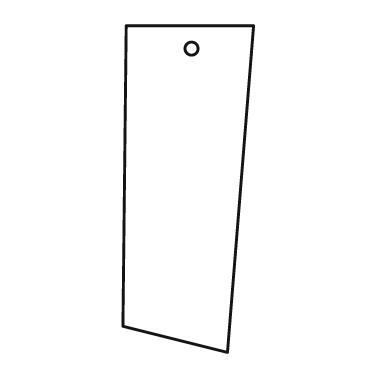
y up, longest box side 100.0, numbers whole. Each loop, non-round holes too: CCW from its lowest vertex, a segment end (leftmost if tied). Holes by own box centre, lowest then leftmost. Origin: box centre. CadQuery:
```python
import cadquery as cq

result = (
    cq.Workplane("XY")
    .moveTo(12.0, -50.0)
    .lineTo(20.0, 50.0)
    .lineTo(-19.0, 50.0)
    .lineTo(-20.0, -42.0)
    .close()
    .moveTo(1.0, 43.0)
    .circle(2.0)
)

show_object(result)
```